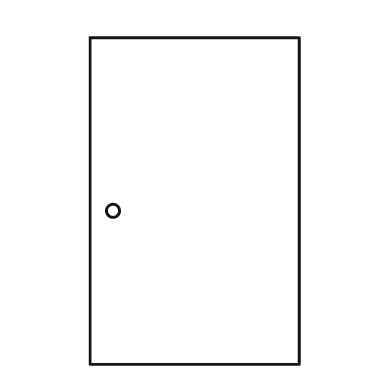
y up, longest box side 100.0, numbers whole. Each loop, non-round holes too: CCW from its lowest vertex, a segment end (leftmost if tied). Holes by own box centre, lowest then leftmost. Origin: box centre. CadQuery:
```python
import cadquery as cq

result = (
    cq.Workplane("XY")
    .moveTo(-32.0, -50.0)
    .lineTo(32.0, -50.0)
    .lineTo(32.0, 50.0)
    .lineTo(-32.0, 50.0)
    .close()
    .moveTo(-25.0, -3.0)
    .circle(2.0)
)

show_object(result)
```